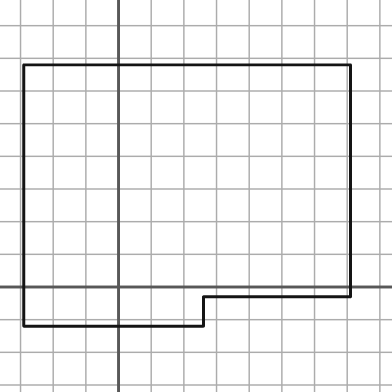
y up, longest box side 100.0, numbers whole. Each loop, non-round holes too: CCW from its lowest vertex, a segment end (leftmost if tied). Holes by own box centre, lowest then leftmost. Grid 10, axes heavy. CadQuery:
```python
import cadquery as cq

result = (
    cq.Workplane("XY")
    .moveTo(-29.0, -12.0)
    .lineTo(26.0, -12.0)
    .lineTo(26.0, -3.0)
    .lineTo(71.0, -3.0)
    .lineTo(71.0, 68.0)
    .lineTo(-29.0, 68.0)
    .close()
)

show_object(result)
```